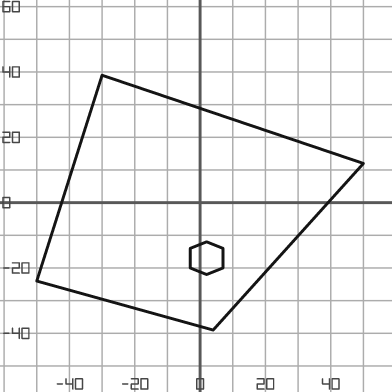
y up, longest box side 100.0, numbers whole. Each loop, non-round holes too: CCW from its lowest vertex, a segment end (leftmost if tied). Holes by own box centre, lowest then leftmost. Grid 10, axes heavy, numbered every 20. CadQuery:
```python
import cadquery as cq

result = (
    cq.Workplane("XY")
    .moveTo(4.0, -39.0)
    .lineTo(50.0, 12.0)
    .lineTo(-30.0, 39.0)
    .lineTo(-50.0, -24.0)
    .close()
    .moveTo(2.0, -22.0)
    .lineTo(7.0, -20.0)
    .lineTo(7.0, -14.0)
    .lineTo(2.0, -12.0)
    .lineTo(-3.0, -14.0)
    .lineTo(-3.0, -20.0)
    .close()
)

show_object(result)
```